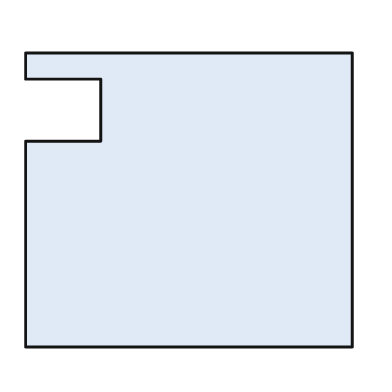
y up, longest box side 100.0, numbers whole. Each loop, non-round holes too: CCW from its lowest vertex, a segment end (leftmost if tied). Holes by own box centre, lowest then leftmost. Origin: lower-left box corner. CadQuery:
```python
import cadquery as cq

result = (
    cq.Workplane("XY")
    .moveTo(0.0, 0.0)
    .lineTo(100.0, 0.0)
    .lineTo(100.0, 90.0)
    .lineTo(0.0, 90.0)
    .lineTo(0.0, 82.0)
    .lineTo(23.0, 82.0)
    .lineTo(23.0, 63.0)
    .lineTo(0.0, 63.0)
    .close()
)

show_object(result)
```